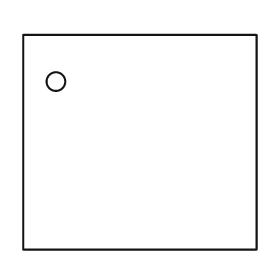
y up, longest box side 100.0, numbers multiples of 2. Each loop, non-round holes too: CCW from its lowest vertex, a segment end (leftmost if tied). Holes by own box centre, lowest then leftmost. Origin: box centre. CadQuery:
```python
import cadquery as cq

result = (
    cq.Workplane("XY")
    .moveTo(-50.0, -46.0)
    .lineTo(50.0, -46.0)
    .lineTo(50.0, 46.0)
    .lineTo(-50.0, 46.0)
    .close()
    .moveTo(-36.0, 26.0)
    .circle(4.0)
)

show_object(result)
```